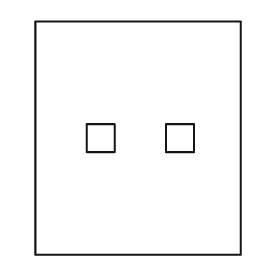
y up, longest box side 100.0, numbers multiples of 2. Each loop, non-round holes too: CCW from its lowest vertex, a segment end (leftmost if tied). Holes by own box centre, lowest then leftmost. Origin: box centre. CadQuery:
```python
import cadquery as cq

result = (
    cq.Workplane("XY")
    .moveTo(-44.0, -50.0)
    .lineTo(44.0, -50.0)
    .lineTo(44.0, 50.0)
    .lineTo(-44.0, 50.0)
    .close()
    .moveTo(-22.0, -6.0)
    .lineTo(-10.0, -6.0)
    .lineTo(-10.0, 6.0)
    .lineTo(-22.0, 6.0)
    .close()
    .moveTo(12.0, -6.0)
    .lineTo(24.0, -6.0)
    .lineTo(24.0, 6.0)
    .lineTo(12.0, 6.0)
    .close()
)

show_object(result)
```